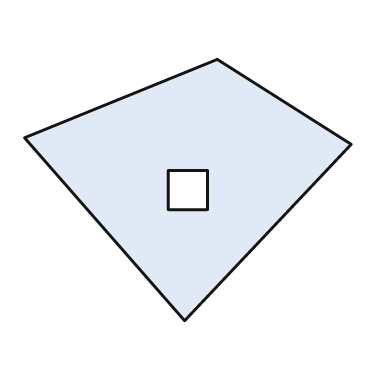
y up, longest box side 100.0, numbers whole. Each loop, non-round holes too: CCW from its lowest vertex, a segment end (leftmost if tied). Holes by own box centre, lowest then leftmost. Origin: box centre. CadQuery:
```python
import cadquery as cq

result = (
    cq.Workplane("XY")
    .moveTo(-1.0, -40.0)
    .lineTo(50.0, 14.0)
    .lineTo(9.0, 40.0)
    .lineTo(-50.0, 16.0)
    .close()
    .moveTo(-6.0, -6.0)
    .lineTo(6.0, -6.0)
    .lineTo(6.0, 6.0)
    .lineTo(-6.0, 6.0)
    .close()
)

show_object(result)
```